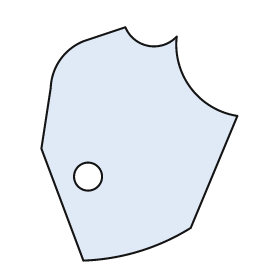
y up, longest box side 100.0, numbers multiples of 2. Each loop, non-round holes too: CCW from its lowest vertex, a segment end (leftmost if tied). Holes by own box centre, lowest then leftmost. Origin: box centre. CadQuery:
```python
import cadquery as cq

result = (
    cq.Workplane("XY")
    .moveTo(-24.0, -50.0)
    .threePointArc((0.0, -46.0), (22.0, -36.0))
    .lineTo(42.0, 12.0)
    .threePointArc((22.0, 24.0), (16.0, 46.0))
    .threePointArc((4.0, 42.0), (-6.0, 50.0))
    .lineTo(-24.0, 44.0)
    .threePointArc((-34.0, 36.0), (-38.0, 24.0))
    .lineTo(-42.0, -2.0)
    .close()
    .moveTo(-22.0, -14.0)
    .circle(6.0)
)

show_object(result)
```